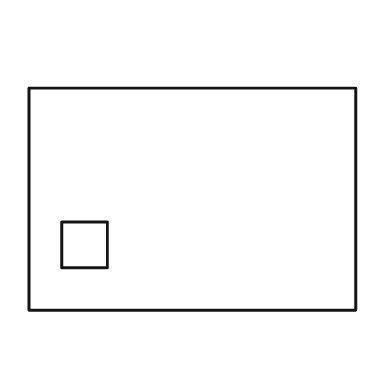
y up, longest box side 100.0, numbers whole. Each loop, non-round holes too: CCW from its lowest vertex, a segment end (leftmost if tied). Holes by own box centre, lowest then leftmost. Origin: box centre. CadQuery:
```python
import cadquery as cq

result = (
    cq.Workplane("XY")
    .moveTo(-50.0, -34.0)
    .lineTo(50.0, -34.0)
    .lineTo(50.0, 34.0)
    .lineTo(-50.0, 34.0)
    .close()
    .moveTo(-40.0, -21.0)
    .lineTo(-26.0, -21.0)
    .lineTo(-26.0, -7.0)
    .lineTo(-40.0, -7.0)
    .close()
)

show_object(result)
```